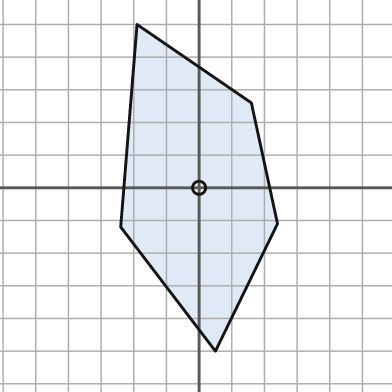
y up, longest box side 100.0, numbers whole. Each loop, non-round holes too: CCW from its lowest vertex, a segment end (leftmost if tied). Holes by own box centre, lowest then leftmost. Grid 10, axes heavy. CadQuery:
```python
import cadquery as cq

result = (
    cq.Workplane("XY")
    .moveTo(5.0, -50.0)
    .lineTo(24.0, -11.0)
    .lineTo(16.0, 26.0)
    .lineTo(-19.0, 50.0)
    .lineTo(-24.0, -12.0)
    .close()
    .moveTo(0.0, 0.0)
    .circle(2.0)
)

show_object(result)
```